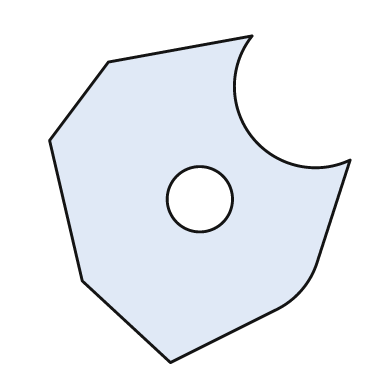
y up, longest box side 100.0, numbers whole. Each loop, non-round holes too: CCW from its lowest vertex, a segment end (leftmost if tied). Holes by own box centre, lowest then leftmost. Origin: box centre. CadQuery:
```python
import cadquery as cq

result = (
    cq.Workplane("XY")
    .moveTo(-9.0, -50.0)
    .lineTo(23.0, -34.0)
    .threePointArc((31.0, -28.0), (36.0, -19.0))
    .lineTo(46.0, 12.0)
    .threePointArc((16.0, 19.0), (16.0, 50.0))
    .lineTo(-28.0, 42.0)
    .lineTo(-46.0, 18.0)
    .lineTo(-36.0, -25.0)
    .close()
    .moveTo(0.0, 0.0)
    .circle(10.0)
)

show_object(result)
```